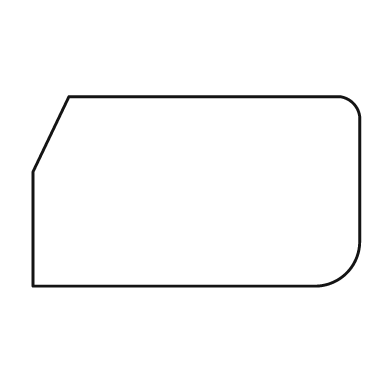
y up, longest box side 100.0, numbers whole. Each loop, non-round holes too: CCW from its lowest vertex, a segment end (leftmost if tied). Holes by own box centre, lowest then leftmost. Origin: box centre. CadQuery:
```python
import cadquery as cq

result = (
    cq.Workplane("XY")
    .moveTo(-50.0, -29.0)
    .lineTo(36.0, -29.0)
    .threePointArc((46.0, -25.0), (50.0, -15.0))
    .lineTo(50.0, 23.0)
    .threePointArc((48.0, 27.0), (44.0, 29.0))
    .lineTo(-39.0, 29.0)
    .lineTo(-50.0, 6.0)
    .close()
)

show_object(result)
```